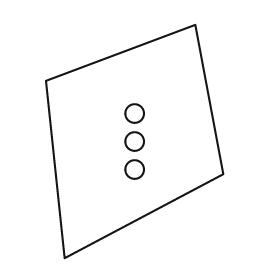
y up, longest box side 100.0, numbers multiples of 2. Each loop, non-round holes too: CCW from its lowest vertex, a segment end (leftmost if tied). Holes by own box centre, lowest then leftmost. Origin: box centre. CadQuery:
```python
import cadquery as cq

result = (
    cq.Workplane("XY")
    .moveTo(-30.0, -50.0)
    .lineTo(38.0, -14.0)
    .lineTo(26.0, 50.0)
    .lineTo(-38.0, 26.0)
    .close()
    .moveTo(0.0, -12.0)
    .circle(4.0)
    .moveTo(0.0, 0.0)
    .circle(4.0)
    .moveTo(0.0, 12.0)
    .circle(4.0)
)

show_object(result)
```